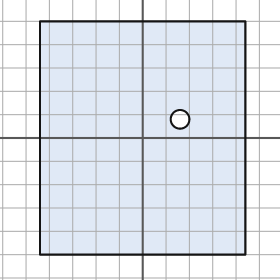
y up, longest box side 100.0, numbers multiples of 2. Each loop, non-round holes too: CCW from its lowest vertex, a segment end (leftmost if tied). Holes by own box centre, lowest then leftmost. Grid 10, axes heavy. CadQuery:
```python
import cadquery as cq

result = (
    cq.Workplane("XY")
    .moveTo(-44.0, -50.0)
    .lineTo(44.0, -50.0)
    .lineTo(44.0, 50.0)
    .lineTo(-44.0, 50.0)
    .close()
    .moveTo(16.0, 8.0)
    .circle(4.0)
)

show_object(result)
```